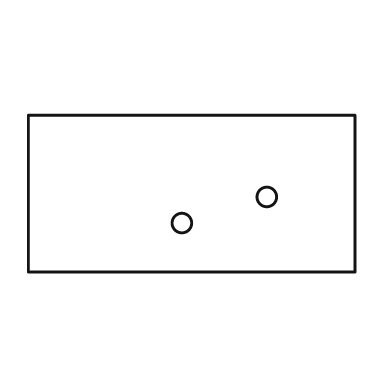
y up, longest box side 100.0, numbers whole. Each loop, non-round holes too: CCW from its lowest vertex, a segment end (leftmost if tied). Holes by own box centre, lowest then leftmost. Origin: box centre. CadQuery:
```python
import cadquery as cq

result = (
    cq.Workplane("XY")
    .moveTo(-50.0, -24.0)
    .lineTo(50.0, -24.0)
    .lineTo(50.0, 24.0)
    .lineTo(-50.0, 24.0)
    .close()
    .moveTo(-3.0, -9.0)
    .circle(3.0)
    .moveTo(23.0, -1.0)
    .circle(3.0)
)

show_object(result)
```